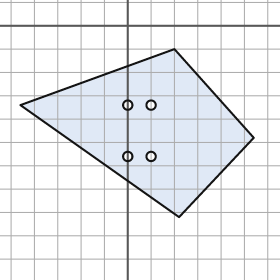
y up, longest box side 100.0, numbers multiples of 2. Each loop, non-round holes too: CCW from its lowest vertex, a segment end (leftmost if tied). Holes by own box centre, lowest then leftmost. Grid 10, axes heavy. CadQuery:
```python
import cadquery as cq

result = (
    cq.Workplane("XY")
    .moveTo(22.0, -82.0)
    .lineTo(54.0, -48.0)
    .lineTo(20.0, -10.0)
    .lineTo(-46.0, -34.0)
    .close()
    .moveTo(0.0, -56.0)
    .circle(2.0)
    .moveTo(10.0, -56.0)
    .circle(2.0)
    .moveTo(0.0, -34.0)
    .circle(2.0)
    .moveTo(10.0, -34.0)
    .circle(2.0)
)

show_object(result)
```